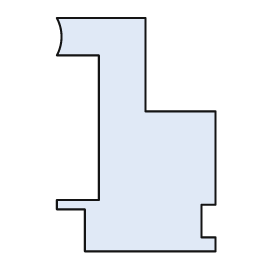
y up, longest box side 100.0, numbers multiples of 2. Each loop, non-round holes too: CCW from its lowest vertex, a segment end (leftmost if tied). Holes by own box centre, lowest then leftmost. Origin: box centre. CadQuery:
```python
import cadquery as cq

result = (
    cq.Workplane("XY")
    .moveTo(-22.0, -50.0)
    .lineTo(34.0, -50.0)
    .lineTo(34.0, -44.0)
    .lineTo(28.0, -44.0)
    .lineTo(28.0, -30.0)
    .lineTo(34.0, -30.0)
    .lineTo(34.0, 10.0)
    .lineTo(4.0, 10.0)
    .lineTo(4.0, 50.0)
    .lineTo(-34.0, 50.0)
    .threePointArc((-32.0, 42.0), (-34.0, 34.0))
    .lineTo(-16.0, 34.0)
    .lineTo(-16.0, -28.0)
    .lineTo(-34.0, -28.0)
    .lineTo(-34.0, -32.0)
    .lineTo(-22.0, -32.0)
    .close()
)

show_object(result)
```